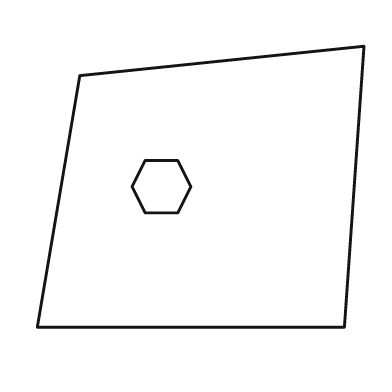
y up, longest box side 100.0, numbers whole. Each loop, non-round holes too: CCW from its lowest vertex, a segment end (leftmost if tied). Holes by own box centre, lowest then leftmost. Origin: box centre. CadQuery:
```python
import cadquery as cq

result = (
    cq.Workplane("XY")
    .moveTo(-50.0, -43.0)
    .lineTo(44.0, -43.0)
    .lineTo(50.0, 43.0)
    .lineTo(-37.0, 34.0)
    .close()
    .moveTo(-17.0, -8.0)
    .lineTo(-7.0, -8.0)
    .lineTo(-3.0, 0.0)
    .lineTo(-7.0, 8.0)
    .lineTo(-17.0, 8.0)
    .lineTo(-21.0, 0.0)
    .close()
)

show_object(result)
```